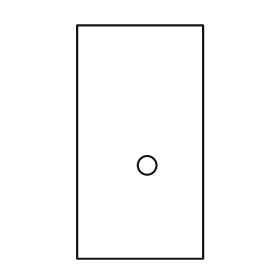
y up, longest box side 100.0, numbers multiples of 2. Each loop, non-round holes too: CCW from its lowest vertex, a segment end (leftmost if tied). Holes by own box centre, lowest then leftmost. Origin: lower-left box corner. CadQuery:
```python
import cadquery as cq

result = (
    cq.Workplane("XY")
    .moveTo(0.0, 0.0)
    .lineTo(54.0, 0.0)
    .lineTo(54.0, 100.0)
    .lineTo(0.0, 100.0)
    .close()
    .moveTo(30.0, 40.0)
    .circle(4.0)
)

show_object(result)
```